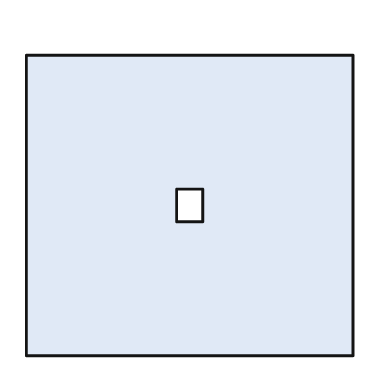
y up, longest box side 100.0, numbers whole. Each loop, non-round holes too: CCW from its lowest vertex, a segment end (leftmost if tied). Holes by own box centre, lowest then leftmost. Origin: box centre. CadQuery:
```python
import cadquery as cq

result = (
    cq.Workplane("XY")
    .moveTo(-50.0, -46.0)
    .lineTo(50.0, -46.0)
    .lineTo(50.0, 46.0)
    .lineTo(-50.0, 46.0)
    .close()
    .moveTo(-4.0, -5.0)
    .lineTo(4.0, -5.0)
    .lineTo(4.0, 5.0)
    .lineTo(-4.0, 5.0)
    .close()
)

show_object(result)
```